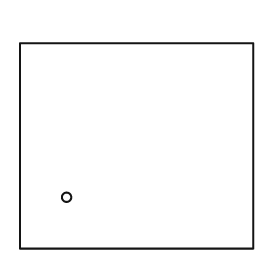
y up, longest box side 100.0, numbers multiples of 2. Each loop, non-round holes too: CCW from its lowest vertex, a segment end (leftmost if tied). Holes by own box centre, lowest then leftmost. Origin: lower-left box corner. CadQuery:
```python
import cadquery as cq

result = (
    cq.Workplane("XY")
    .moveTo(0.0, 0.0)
    .lineTo(100.0, 0.0)
    .lineTo(100.0, 88.0)
    .lineTo(0.0, 88.0)
    .close()
    .moveTo(20.0, 22.0)
    .circle(2.0)
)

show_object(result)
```